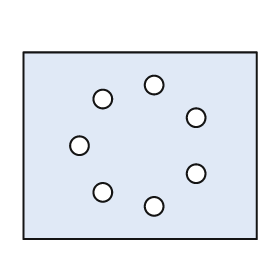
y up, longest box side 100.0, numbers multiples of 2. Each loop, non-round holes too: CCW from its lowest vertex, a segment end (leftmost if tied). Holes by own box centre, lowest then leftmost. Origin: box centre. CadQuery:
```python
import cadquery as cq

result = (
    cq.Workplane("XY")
    .moveTo(-50.0, -40.0)
    .lineTo(50.0, -40.0)
    .lineTo(50.0, 40.0)
    .lineTo(-50.0, 40.0)
    .close()
    .moveTo(6.0, -26.0)
    .circle(4.0)
    .moveTo(-16.0, -20.0)
    .circle(4.0)
    .moveTo(24.0, -12.0)
    .circle(4.0)
    .moveTo(-26.0, 0.0)
    .circle(4.0)
    .moveTo(24.0, 12.0)
    .circle(4.0)
    .moveTo(-16.0, 20.0)
    .circle(4.0)
    .moveTo(6.0, 26.0)
    .circle(4.0)
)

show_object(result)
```